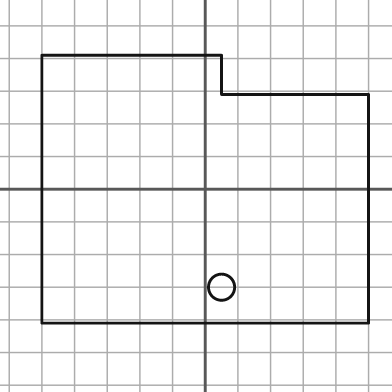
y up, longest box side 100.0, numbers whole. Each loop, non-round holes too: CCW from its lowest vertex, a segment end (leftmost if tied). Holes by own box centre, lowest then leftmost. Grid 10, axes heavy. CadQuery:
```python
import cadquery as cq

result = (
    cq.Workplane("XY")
    .moveTo(-50.0, -41.0)
    .lineTo(50.0, -41.0)
    .lineTo(50.0, 29.0)
    .lineTo(5.0, 29.0)
    .lineTo(5.0, 41.0)
    .lineTo(-50.0, 41.0)
    .close()
    .moveTo(5.0, -30.0)
    .circle(4.0)
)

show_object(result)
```